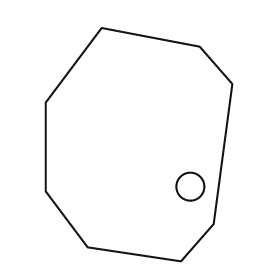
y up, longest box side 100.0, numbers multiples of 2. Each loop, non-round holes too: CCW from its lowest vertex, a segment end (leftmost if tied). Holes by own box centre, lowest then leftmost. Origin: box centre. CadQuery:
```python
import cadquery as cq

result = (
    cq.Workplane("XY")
    .moveTo(18.0, -50.0)
    .lineTo(32.0, -34.0)
    .lineTo(40.0, 26.0)
    .lineTo(26.0, 42.0)
    .lineTo(-16.0, 50.0)
    .lineTo(-40.0, 18.0)
    .lineTo(-40.0, -20.0)
    .lineTo(-22.0, -44.0)
    .close()
    .moveTo(22.0, -18.0)
    .circle(6.0)
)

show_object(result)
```